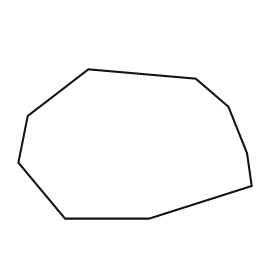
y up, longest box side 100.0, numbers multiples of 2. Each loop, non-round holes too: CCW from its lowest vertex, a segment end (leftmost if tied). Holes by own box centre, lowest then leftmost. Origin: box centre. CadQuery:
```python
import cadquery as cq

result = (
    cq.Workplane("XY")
    .moveTo(-30.0, -32.0)
    .lineTo(6.0, -32.0)
    .lineTo(50.0, -18.0)
    .lineTo(48.0, -4.0)
    .lineTo(40.0, 16.0)
    .lineTo(26.0, 28.0)
    .lineTo(-20.0, 32.0)
    .lineTo(-46.0, 12.0)
    .lineTo(-50.0, -8.0)
    .close()
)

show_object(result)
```